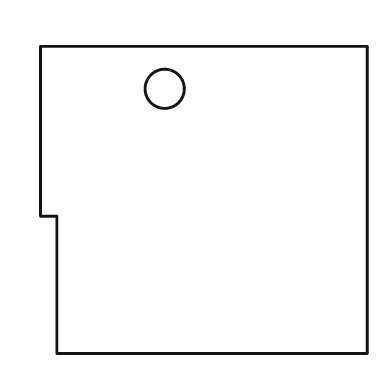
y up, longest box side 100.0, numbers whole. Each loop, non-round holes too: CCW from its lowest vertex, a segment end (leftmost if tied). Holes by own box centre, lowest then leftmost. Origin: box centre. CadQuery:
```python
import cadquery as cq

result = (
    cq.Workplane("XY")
    .moveTo(-45.0, -47.0)
    .lineTo(50.0, -47.0)
    .lineTo(50.0, 47.0)
    .lineTo(-50.0, 47.0)
    .lineTo(-50.0, -5.0)
    .lineTo(-45.0, -5.0)
    .close()
    .moveTo(-12.0, 34.0)
    .circle(6.0)
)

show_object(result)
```